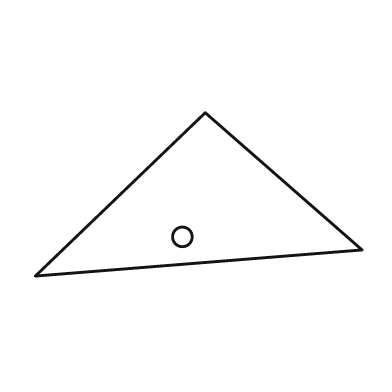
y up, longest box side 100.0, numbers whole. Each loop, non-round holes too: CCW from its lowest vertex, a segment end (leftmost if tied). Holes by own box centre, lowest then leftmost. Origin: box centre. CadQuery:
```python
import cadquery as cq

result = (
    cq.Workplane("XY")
    .moveTo(-50.0, -25.0)
    .lineTo(50.0, -17.0)
    .lineTo(2.0, 25.0)
    .close()
    .moveTo(-5.0, -13.0)
    .circle(3.0)
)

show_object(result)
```